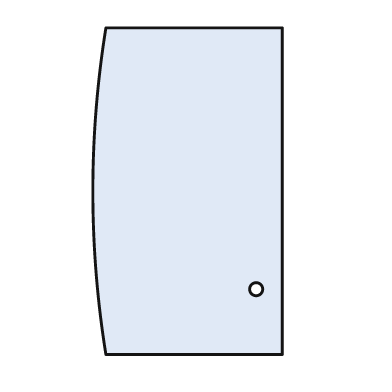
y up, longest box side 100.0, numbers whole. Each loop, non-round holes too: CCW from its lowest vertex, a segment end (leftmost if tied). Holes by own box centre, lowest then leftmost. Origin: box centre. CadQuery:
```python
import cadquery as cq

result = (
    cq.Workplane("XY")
    .moveTo(-25.0, -50.0)
    .lineTo(29.0, -50.0)
    .lineTo(29.0, 50.0)
    .lineTo(-25.0, 50.0)
    .threePointArc((-29.0, 0.0), (-25.0, -50.0))
    .close()
    .moveTo(21.0, -30.0)
    .circle(2.0)
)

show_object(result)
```